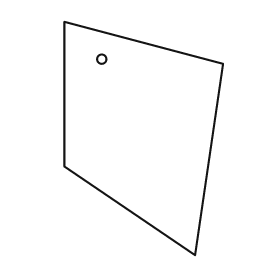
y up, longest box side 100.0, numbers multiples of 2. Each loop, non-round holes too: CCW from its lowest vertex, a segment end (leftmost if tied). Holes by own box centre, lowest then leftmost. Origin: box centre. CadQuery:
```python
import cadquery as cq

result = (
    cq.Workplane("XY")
    .moveTo(22.0, -50.0)
    .lineTo(34.0, 32.0)
    .lineTo(-34.0, 50.0)
    .lineTo(-34.0, -12.0)
    .close()
    .moveTo(-18.0, 34.0)
    .circle(2.0)
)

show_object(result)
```